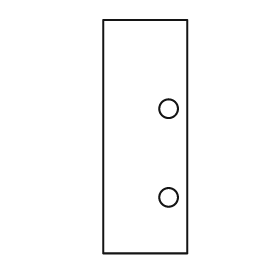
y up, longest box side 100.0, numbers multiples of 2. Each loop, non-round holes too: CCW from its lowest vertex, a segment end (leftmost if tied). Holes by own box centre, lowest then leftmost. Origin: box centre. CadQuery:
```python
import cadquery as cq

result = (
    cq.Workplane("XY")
    .moveTo(-18.0, -50.0)
    .lineTo(18.0, -50.0)
    .lineTo(18.0, 50.0)
    .lineTo(-18.0, 50.0)
    .close()
    .moveTo(10.0, -26.0)
    .circle(4.0)
    .moveTo(10.0, 12.0)
    .circle(4.0)
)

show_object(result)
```